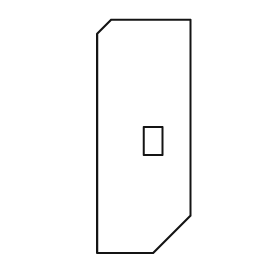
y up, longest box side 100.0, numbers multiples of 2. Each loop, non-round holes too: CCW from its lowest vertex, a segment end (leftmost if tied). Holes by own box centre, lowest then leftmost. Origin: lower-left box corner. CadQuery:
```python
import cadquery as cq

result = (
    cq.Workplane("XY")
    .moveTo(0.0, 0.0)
    .lineTo(24.0, 0.0)
    .lineTo(40.0, 16.0)
    .lineTo(40.0, 100.0)
    .lineTo(6.0, 100.0)
    .lineTo(0.0, 94.0)
    .close()
    .moveTo(20.0, 42.0)
    .lineTo(28.0, 42.0)
    .lineTo(28.0, 54.0)
    .lineTo(20.0, 54.0)
    .close()
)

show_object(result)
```